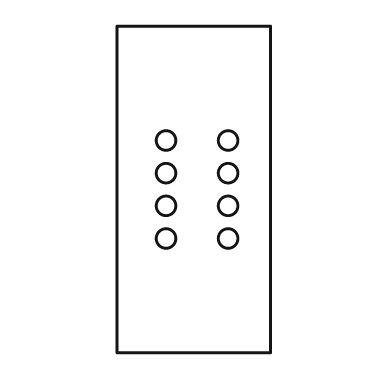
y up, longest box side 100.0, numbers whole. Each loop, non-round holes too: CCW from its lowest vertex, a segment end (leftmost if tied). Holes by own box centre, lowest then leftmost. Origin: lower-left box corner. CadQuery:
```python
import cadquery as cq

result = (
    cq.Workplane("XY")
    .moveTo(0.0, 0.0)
    .lineTo(47.0, 0.0)
    .lineTo(47.0, 100.0)
    .lineTo(0.0, 100.0)
    .close()
    .moveTo(15.0, 35.0)
    .circle(3.0)
    .moveTo(34.0, 35.0)
    .circle(3.0)
    .moveTo(15.0, 45.0)
    .circle(3.0)
    .moveTo(34.0, 45.0)
    .circle(3.0)
    .moveTo(15.0, 55.0)
    .circle(3.0)
    .moveTo(34.0, 55.0)
    .circle(3.0)
    .moveTo(15.0, 65.0)
    .circle(3.0)
    .moveTo(34.0, 65.0)
    .circle(3.0)
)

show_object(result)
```